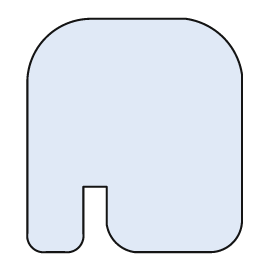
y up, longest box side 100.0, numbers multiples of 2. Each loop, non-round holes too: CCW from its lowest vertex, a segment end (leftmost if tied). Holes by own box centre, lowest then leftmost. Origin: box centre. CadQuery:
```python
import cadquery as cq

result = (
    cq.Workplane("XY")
    .moveTo(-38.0, -50.0)
    .lineTo(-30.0, -50.0)
    .threePointArc((-24.0, -48.0), (-22.0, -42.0))
    .lineTo(-22.0, -22.0)
    .lineTo(-12.0, -22.0)
    .lineTo(-12.0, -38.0)
    .threePointArc((-8.0, -46.0), (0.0, -50.0))
    .lineTo(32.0, -50.0)
    .threePointArc((42.0, -46.0), (46.0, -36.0))
    .lineTo(46.0, 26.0)
    .threePointArc((38.0, 42.0), (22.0, 50.0))
    .lineTo(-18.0, 50.0)
    .threePointArc((-38.0, 42.0), (-46.0, 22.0))
    .lineTo(-46.0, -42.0)
    .threePointArc((-44.0, -48.0), (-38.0, -50.0))
    .close()
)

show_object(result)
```